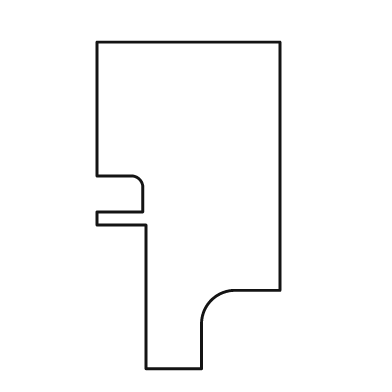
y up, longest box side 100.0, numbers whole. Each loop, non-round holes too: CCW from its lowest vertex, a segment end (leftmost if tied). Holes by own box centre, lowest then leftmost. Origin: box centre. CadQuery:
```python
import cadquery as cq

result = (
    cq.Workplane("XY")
    .moveTo(-13.0, -50.0)
    .lineTo(4.0, -50.0)
    .lineTo(4.0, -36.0)
    .threePointArc((7.0, -29.0), (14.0, -26.0))
    .lineTo(28.0, -26.0)
    .lineTo(28.0, 50.0)
    .lineTo(-28.0, 50.0)
    .lineTo(-28.0, 9.0)
    .lineTo(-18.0, 9.0)
    .threePointArc((-15.0, 8.0), (-14.0, 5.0))
    .lineTo(-14.0, -2.0)
    .lineTo(-28.0, -2.0)
    .lineTo(-28.0, -6.0)
    .lineTo(-13.0, -6.0)
    .close()
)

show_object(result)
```